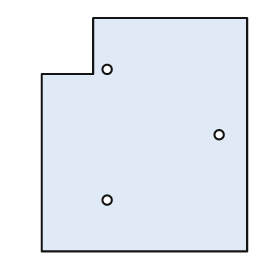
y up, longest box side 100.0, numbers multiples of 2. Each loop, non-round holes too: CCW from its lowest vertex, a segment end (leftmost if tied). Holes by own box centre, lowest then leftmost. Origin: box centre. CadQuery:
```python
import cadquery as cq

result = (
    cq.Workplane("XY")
    .moveTo(-44.0, -50.0)
    .lineTo(44.0, -50.0)
    .lineTo(44.0, 50.0)
    .lineTo(-22.0, 50.0)
    .lineTo(-22.0, 26.0)
    .lineTo(-44.0, 26.0)
    .close()
    .moveTo(-16.0, -28.0)
    .circle(2.0)
    .moveTo(32.0, 0.0)
    .circle(2.0)
    .moveTo(-16.0, 28.0)
    .circle(2.0)
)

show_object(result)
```